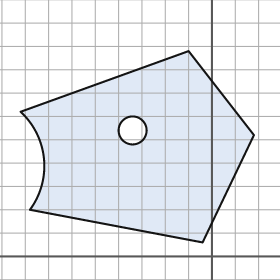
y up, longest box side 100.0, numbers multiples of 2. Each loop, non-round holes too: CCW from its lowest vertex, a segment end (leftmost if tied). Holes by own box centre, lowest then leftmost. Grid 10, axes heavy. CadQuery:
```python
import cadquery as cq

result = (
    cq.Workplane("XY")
    .moveTo(-4.0, 6.0)
    .lineTo(18.0, 52.0)
    .lineTo(-10.0, 88.0)
    .lineTo(-82.0, 62.0)
    .threePointArc((-72.0, 42.0), (-78.0, 20.0))
    .close()
    .moveTo(-34.0, 54.0)
    .circle(6.0)
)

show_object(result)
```